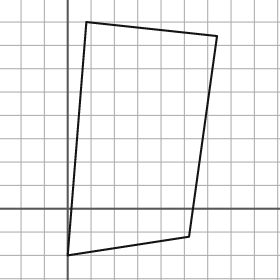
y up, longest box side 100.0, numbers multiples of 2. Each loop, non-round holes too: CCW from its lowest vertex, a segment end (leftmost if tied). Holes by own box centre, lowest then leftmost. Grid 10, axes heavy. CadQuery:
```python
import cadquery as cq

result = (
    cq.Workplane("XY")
    .moveTo(0.0, -20.0)
    .lineTo(52.0, -12.0)
    .lineTo(64.0, 74.0)
    .lineTo(8.0, 80.0)
    .close()
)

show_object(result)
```